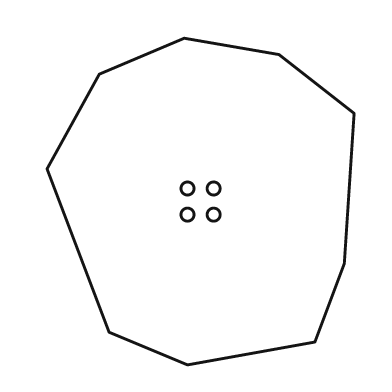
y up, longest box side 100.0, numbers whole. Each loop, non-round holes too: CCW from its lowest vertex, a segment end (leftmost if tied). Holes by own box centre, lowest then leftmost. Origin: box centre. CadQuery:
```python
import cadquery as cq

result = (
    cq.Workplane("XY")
    .moveTo(-4.0, -50.0)
    .lineTo(35.0, -43.0)
    .lineTo(44.0, -19.0)
    .lineTo(47.0, 27.0)
    .lineTo(24.0, 45.0)
    .lineTo(-5.0, 50.0)
    .lineTo(-31.0, 39.0)
    .lineTo(-47.0, 10.0)
    .lineTo(-28.0, -40.0)
    .close()
    .moveTo(-4.0, -4.0)
    .circle(2.0)
    .moveTo(4.0, -4.0)
    .circle(2.0)
    .moveTo(-4.0, 4.0)
    .circle(2.0)
    .moveTo(4.0, 4.0)
    .circle(2.0)
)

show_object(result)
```